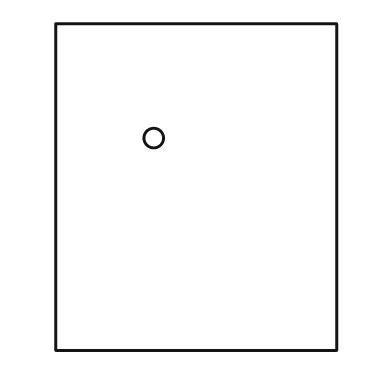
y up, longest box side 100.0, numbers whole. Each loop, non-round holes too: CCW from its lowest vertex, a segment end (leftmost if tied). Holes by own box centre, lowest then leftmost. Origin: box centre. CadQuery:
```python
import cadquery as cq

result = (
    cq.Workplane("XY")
    .moveTo(-43.0, -50.0)
    .lineTo(43.0, -50.0)
    .lineTo(43.0, 50.0)
    .lineTo(-43.0, 50.0)
    .close()
    .moveTo(-13.0, 15.0)
    .circle(3.0)
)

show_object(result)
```